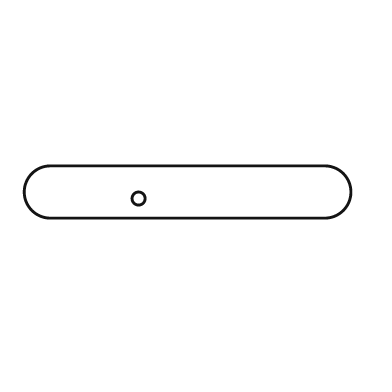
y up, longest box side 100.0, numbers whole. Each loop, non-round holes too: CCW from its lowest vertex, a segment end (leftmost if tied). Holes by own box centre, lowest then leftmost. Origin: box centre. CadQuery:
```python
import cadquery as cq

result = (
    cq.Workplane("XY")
    .moveTo(-42.0, -8.0)
    .lineTo(42.0, -8.0)
    .threePointArc((50.0, 0.0), (42.0, 8.0))
    .lineTo(-42.0, 8.0)
    .threePointArc((-50.0, 0.0), (-42.0, -8.0))
    .close()
    .moveTo(-15.0, -2.0)
    .circle(2.0)
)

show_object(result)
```